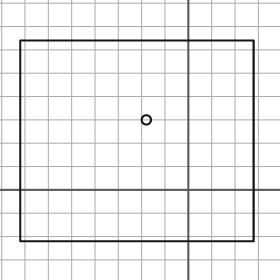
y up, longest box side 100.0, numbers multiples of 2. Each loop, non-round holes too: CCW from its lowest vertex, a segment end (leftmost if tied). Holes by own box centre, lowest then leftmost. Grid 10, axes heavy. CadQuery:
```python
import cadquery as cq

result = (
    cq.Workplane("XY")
    .moveTo(-72.0, -22.0)
    .lineTo(28.0, -22.0)
    .lineTo(28.0, 64.0)
    .lineTo(-72.0, 64.0)
    .close()
    .moveTo(-18.0, 30.0)
    .circle(2.0)
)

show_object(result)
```